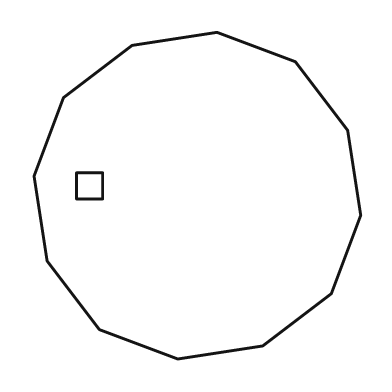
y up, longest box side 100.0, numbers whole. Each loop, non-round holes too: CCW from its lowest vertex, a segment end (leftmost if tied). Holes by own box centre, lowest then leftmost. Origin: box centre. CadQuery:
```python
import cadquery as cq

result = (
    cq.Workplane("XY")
    .moveTo(-6.0, -50.0)
    .lineTo(20.0, -46.0)
    .lineTo(41.0, -30.0)
    .lineTo(50.0, -6.0)
    .lineTo(46.0, 20.0)
    .lineTo(30.0, 41.0)
    .lineTo(6.0, 50.0)
    .lineTo(-20.0, 46.0)
    .lineTo(-41.0, 30.0)
    .lineTo(-50.0, 6.0)
    .lineTo(-46.0, -20.0)
    .lineTo(-30.0, -41.0)
    .close()
    .moveTo(-37.0, -1.0)
    .lineTo(-29.0, -1.0)
    .lineTo(-29.0, 7.0)
    .lineTo(-37.0, 7.0)
    .close()
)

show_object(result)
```